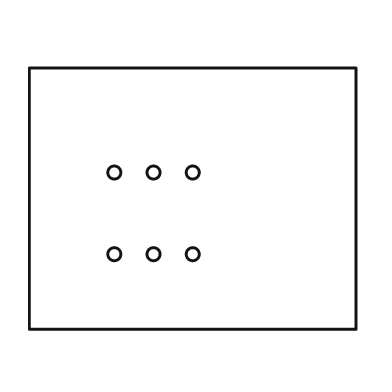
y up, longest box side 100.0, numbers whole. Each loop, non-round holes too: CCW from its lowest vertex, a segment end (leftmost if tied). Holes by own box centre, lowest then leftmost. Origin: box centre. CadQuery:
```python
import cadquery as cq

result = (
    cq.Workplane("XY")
    .moveTo(-50.0, -40.0)
    .lineTo(50.0, -40.0)
    .lineTo(50.0, 40.0)
    .lineTo(-50.0, 40.0)
    .close()
    .moveTo(-24.0, -17.0)
    .circle(2.0)
    .moveTo(-12.0, -17.0)
    .circle(2.0)
    .moveTo(0.0, -17.0)
    .circle(2.0)
    .moveTo(-24.0, 8.0)
    .circle(2.0)
    .moveTo(-12.0, 8.0)
    .circle(2.0)
    .moveTo(0.0, 8.0)
    .circle(2.0)
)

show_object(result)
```